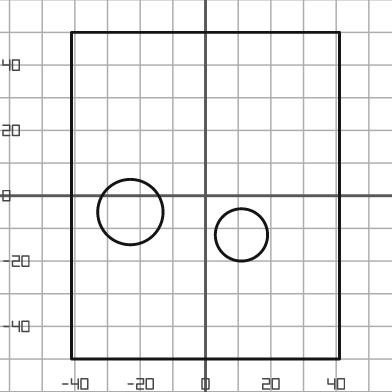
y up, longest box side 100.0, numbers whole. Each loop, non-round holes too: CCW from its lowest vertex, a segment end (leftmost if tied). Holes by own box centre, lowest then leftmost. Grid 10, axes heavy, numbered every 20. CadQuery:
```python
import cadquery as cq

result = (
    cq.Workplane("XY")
    .moveTo(-41.0, -50.0)
    .lineTo(41.0, -50.0)
    .lineTo(41.0, 50.0)
    .lineTo(-41.0, 50.0)
    .close()
    .moveTo(11.0, -12.0)
    .circle(8.0)
    .moveTo(-23.0, -5.0)
    .circle(10.0)
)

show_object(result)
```